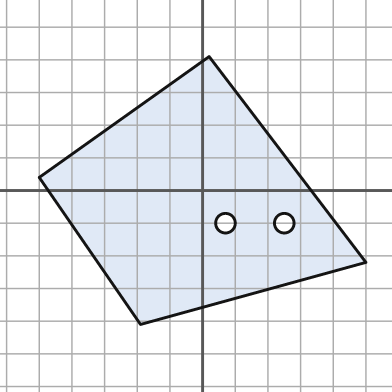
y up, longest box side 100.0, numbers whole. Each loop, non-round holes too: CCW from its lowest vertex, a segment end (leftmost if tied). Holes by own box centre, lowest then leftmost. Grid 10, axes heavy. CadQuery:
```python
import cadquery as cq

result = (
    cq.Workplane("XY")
    .moveTo(-19.0, -41.0)
    .lineTo(50.0, -22.0)
    .lineTo(2.0, 41.0)
    .lineTo(-50.0, 4.0)
    .close()
    .moveTo(7.0, -10.0)
    .circle(3.0)
    .moveTo(25.0, -10.0)
    .circle(3.0)
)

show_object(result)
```